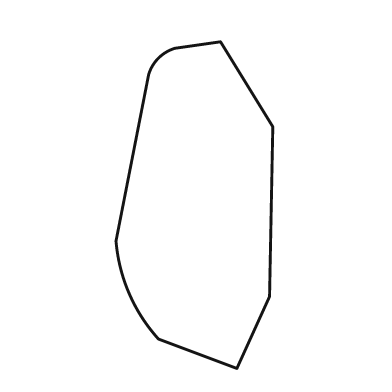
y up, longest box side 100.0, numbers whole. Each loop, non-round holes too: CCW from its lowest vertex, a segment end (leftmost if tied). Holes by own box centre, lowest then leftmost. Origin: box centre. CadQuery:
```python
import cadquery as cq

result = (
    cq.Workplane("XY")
    .moveTo(13.0, -50.0)
    .lineTo(23.0, -28.0)
    .lineTo(24.0, 24.0)
    .lineTo(8.0, 50.0)
    .lineTo(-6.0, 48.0)
    .threePointArc((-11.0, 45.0), (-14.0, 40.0))
    .lineTo(-24.0, -11.0)
    .threePointArc((-20.0, -27.0), (-11.0, -41.0))
    .close()
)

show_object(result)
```